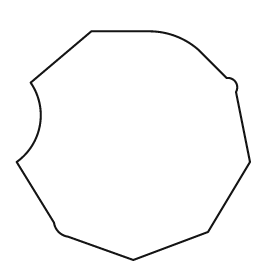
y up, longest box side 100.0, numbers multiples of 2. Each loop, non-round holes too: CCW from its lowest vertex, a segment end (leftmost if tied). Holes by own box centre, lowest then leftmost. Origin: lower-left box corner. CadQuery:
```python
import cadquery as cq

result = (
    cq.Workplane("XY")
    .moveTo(50.0, 0.0)
    .lineTo(82.0, 12.0)
    .lineTo(100.0, 42.0)
    .lineTo(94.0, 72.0)
    .threePointArc((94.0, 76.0), (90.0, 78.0))
    .lineTo(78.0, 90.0)
    .threePointArc((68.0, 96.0), (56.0, 98.0))
    .lineTo(32.0, 98.0)
    .lineTo(6.0, 76.0)
    .threePointArc((10.0, 58.0), (0.0, 42.0))
    .lineTo(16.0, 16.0)
    .threePointArc((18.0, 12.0), (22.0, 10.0))
    .close()
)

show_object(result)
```